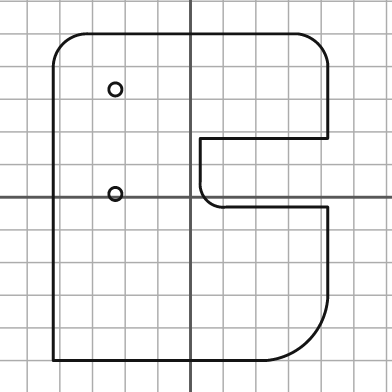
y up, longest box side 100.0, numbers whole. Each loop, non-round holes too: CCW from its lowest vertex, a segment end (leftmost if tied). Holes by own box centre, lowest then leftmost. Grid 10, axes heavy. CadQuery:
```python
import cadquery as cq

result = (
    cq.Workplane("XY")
    .moveTo(-42.0, -50.0)
    .lineTo(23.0, -50.0)
    .threePointArc((36.0, -44.0), (42.0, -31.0))
    .lineTo(42.0, -3.0)
    .lineTo(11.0, -3.0)
    .threePointArc((5.0, -1.0), (3.0, 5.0))
    .lineTo(3.0, 18.0)
    .lineTo(42.0, 18.0)
    .lineTo(42.0, 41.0)
    .threePointArc((39.0, 47.0), (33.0, 50.0))
    .lineTo(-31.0, 50.0)
    .threePointArc((-39.0, 47.0), (-42.0, 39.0))
    .close()
    .moveTo(-23.0, 1.0)
    .circle(2.0)
    .moveTo(-23.0, 33.0)
    .circle(2.0)
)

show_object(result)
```